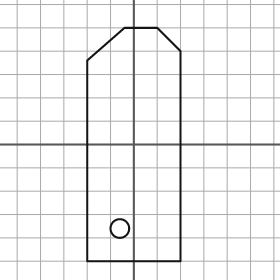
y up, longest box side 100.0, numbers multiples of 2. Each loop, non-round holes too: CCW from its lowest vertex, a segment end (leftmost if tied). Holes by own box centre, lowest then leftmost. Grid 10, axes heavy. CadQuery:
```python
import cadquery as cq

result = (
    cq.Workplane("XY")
    .moveTo(-20.0, -50.0)
    .lineTo(20.0, -50.0)
    .lineTo(20.0, 40.0)
    .lineTo(10.0, 50.0)
    .lineTo(-4.0, 50.0)
    .lineTo(-20.0, 36.0)
    .close()
    .moveTo(-6.0, -36.0)
    .circle(4.0)
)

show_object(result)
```